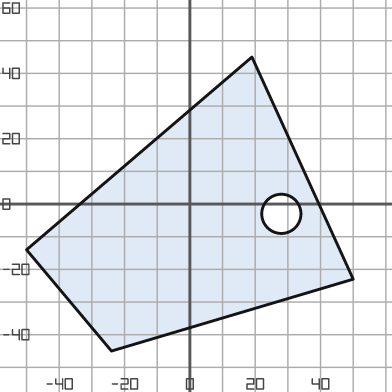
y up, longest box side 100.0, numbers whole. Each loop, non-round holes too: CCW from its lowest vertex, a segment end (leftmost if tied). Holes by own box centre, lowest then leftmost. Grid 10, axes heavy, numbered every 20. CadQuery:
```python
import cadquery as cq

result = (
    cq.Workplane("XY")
    .moveTo(-24.0, -45.0)
    .lineTo(50.0, -23.0)
    .lineTo(19.0, 45.0)
    .lineTo(-50.0, -14.0)
    .close()
    .moveTo(28.0, -3.0)
    .circle(6.0)
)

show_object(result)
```